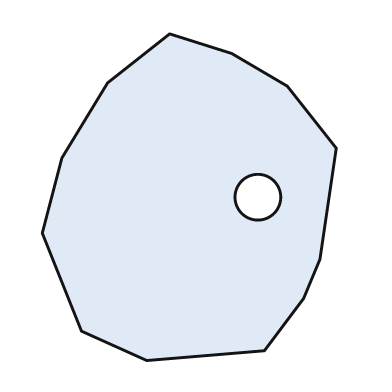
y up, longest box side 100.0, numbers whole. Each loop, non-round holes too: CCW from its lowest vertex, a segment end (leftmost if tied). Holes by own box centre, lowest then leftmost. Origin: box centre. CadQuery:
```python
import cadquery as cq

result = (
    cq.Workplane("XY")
    .moveTo(-13.0, -50.0)
    .lineTo(23.0, -47.0)
    .lineTo(35.0, -31.0)
    .lineTo(40.0, -19.0)
    .lineTo(45.0, 15.0)
    .lineTo(30.0, 34.0)
    .lineTo(13.0, 44.0)
    .lineTo(-6.0, 50.0)
    .lineTo(-25.0, 35.0)
    .lineTo(-39.0, 12.0)
    .lineTo(-45.0, -11.0)
    .lineTo(-33.0, -41.0)
    .close()
    .moveTo(21.0, 0.0)
    .circle(7.0)
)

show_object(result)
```